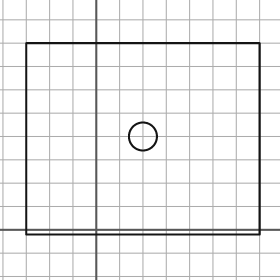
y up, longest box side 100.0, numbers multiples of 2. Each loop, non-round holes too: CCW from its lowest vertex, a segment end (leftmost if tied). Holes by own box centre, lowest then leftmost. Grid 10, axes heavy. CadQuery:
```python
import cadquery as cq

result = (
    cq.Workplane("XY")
    .moveTo(-30.0, -2.0)
    .lineTo(70.0, -2.0)
    .lineTo(70.0, 80.0)
    .lineTo(-30.0, 80.0)
    .close()
    .moveTo(20.0, 40.0)
    .circle(6.0)
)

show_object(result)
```